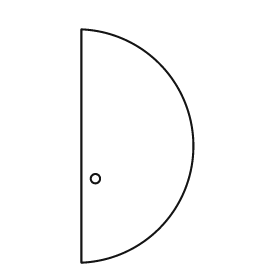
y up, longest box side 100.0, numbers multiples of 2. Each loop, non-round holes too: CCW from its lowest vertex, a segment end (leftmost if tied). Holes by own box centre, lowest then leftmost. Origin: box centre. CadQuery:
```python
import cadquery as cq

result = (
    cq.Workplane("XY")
    .moveTo(-24.0, -50.0)
    .threePointArc((24.0, 0.0), (-24.0, 50.0))
    .close()
    .moveTo(-18.0, -14.0)
    .circle(2.0)
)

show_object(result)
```